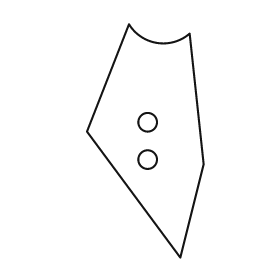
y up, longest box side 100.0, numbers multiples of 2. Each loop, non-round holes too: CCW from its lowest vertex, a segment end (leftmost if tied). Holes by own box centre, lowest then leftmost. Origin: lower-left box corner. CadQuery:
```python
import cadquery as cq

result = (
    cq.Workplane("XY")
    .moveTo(40.0, 0.0)
    .lineTo(50.0, 40.0)
    .lineTo(44.0, 96.0)
    .threePointArc((30.0, 92.0), (18.0, 100.0))
    .lineTo(0.0, 54.0)
    .close()
    .moveTo(26.0, 42.0)
    .circle(4.0)
    .moveTo(26.0, 58.0)
    .circle(4.0)
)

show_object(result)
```